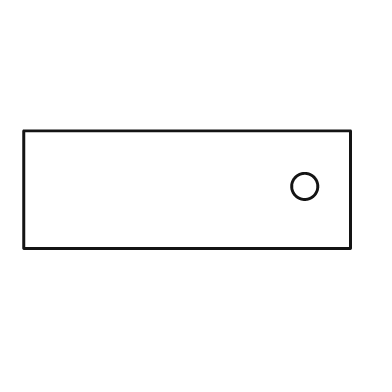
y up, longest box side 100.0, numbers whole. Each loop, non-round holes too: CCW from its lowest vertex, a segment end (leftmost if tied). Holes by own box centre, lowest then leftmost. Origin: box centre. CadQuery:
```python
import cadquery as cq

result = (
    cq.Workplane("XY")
    .moveTo(-50.0, -18.0)
    .lineTo(50.0, -18.0)
    .lineTo(50.0, 18.0)
    .lineTo(-50.0, 18.0)
    .close()
    .moveTo(36.0, 1.0)
    .circle(4.0)
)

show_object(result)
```